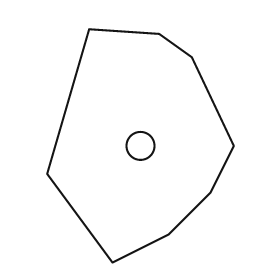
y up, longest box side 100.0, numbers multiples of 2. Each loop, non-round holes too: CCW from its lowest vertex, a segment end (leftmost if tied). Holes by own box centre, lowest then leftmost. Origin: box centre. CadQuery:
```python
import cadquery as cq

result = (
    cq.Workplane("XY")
    .moveTo(-12.0, -50.0)
    .lineTo(12.0, -38.0)
    .lineTo(30.0, -20.0)
    .lineTo(40.0, 0.0)
    .lineTo(22.0, 38.0)
    .lineTo(8.0, 48.0)
    .lineTo(-22.0, 50.0)
    .lineTo(-40.0, -12.0)
    .close()
    .moveTo(0.0, 0.0)
    .circle(6.0)
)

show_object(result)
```